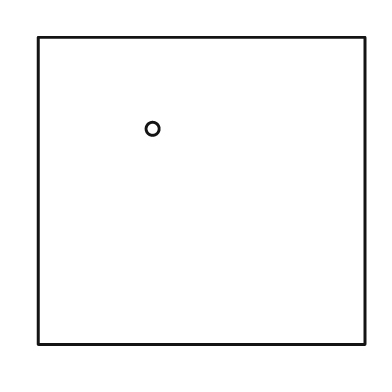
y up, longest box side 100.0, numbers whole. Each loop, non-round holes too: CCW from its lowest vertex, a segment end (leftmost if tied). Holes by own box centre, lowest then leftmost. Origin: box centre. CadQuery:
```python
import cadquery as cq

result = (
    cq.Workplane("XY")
    .moveTo(-50.0, -47.0)
    .lineTo(50.0, -47.0)
    .lineTo(50.0, 47.0)
    .lineTo(-50.0, 47.0)
    .close()
    .moveTo(-15.0, 19.0)
    .circle(2.0)
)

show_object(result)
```